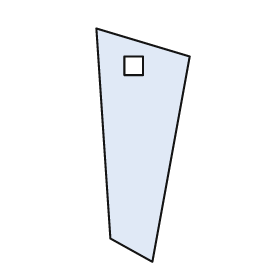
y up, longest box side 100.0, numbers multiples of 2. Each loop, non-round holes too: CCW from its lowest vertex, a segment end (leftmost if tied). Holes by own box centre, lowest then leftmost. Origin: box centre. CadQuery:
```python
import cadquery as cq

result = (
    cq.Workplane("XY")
    .moveTo(4.0, -50.0)
    .lineTo(20.0, 38.0)
    .lineTo(-20.0, 50.0)
    .lineTo(-14.0, -40.0)
    .close()
    .moveTo(-8.0, 30.0)
    .lineTo(0.0, 30.0)
    .lineTo(0.0, 38.0)
    .lineTo(-8.0, 38.0)
    .close()
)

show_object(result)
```